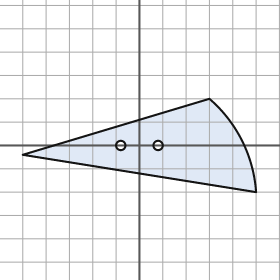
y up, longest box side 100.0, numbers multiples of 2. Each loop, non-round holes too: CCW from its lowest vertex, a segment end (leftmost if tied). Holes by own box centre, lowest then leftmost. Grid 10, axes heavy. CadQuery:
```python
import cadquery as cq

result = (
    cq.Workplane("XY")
    .moveTo(50.0, -20.0)
    .threePointArc((44.0, 2.0), (30.0, 20.0))
    .lineTo(-50.0, -4.0)
    .close()
    .moveTo(-8.0, 0.0)
    .circle(2.0)
    .moveTo(8.0, 0.0)
    .circle(2.0)
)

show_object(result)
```